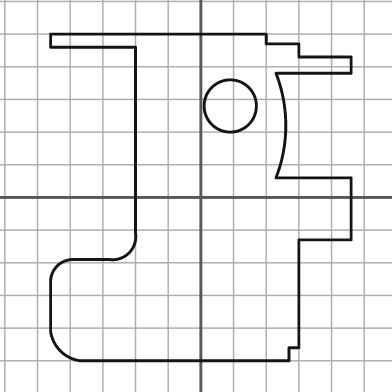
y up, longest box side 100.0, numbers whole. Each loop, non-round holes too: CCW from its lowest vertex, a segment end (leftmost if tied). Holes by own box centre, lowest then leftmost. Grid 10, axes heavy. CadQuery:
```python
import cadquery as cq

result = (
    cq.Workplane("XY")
    .moveTo(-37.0, -50.0)
    .lineTo(27.0, -50.0)
    .lineTo(27.0, -46.0)
    .lineTo(30.0, -46.0)
    .lineTo(30.0, -13.0)
    .lineTo(46.0, -13.0)
    .lineTo(46.0, 6.0)
    .lineTo(23.0, 6.0)
    .threePointArc((26.0, 22.0), (23.0, 38.0))
    .lineTo(46.0, 38.0)
    .lineTo(46.0, 43.0)
    .lineTo(30.0, 43.0)
    .lineTo(30.0, 47.0)
    .lineTo(20.0, 47.0)
    .lineTo(20.0, 50.0)
    .lineTo(-46.0, 50.0)
    .lineTo(-46.0, 46.0)
    .lineTo(-20.0, 46.0)
    .lineTo(-20.0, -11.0)
    .threePointArc((-22.0, -17.0), (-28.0, -19.0))
    .lineTo(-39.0, -19.0)
    .threePointArc((-44.0, -21.0), (-46.0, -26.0))
    .lineTo(-46.0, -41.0)
    .threePointArc((-43.0, -47.0), (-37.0, -50.0))
    .close()
    .moveTo(9.0, 28.0)
    .circle(8.0)
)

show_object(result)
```